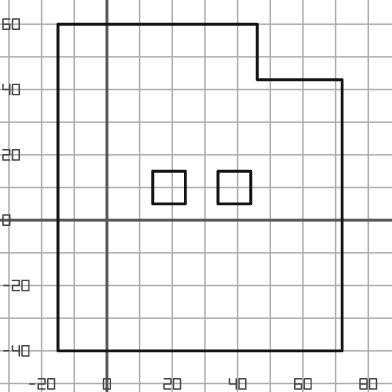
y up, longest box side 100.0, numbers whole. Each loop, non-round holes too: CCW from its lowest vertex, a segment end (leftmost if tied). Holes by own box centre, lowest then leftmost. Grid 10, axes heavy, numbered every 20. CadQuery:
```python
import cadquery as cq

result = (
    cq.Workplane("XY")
    .moveTo(-15.0, -40.0)
    .lineTo(72.0, -40.0)
    .lineTo(72.0, 43.0)
    .lineTo(46.0, 43.0)
    .lineTo(46.0, 60.0)
    .lineTo(-15.0, 60.0)
    .close()
    .moveTo(14.0, 5.0)
    .lineTo(24.0, 5.0)
    .lineTo(24.0, 15.0)
    .lineTo(14.0, 15.0)
    .close()
    .moveTo(34.0, 5.0)
    .lineTo(44.0, 5.0)
    .lineTo(44.0, 15.0)
    .lineTo(34.0, 15.0)
    .close()
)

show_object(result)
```